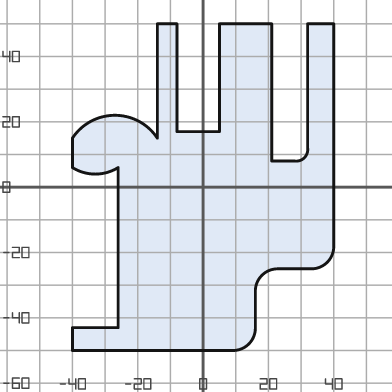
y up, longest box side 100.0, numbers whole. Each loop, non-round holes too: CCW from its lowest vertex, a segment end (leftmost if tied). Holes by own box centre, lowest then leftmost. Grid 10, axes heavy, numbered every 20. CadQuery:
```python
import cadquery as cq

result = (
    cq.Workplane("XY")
    .moveTo(-40.0, -50.0)
    .lineTo(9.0, -50.0)
    .threePointArc((14.0, -48.0), (16.0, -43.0))
    .lineTo(16.0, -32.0)
    .threePointArc((18.0, -27.0), (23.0, -25.0))
    .lineTo(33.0, -25.0)
    .threePointArc((38.0, -23.0), (40.0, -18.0))
    .lineTo(40.0, 50.0)
    .lineTo(32.0, 50.0)
    .lineTo(32.0, 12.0)
    .threePointArc((31.0, 9.0), (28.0, 8.0))
    .lineTo(21.0, 8.0)
    .lineTo(21.0, 50.0)
    .lineTo(5.0, 50.0)
    .lineTo(5.0, 17.0)
    .lineTo(-8.0, 17.0)
    .lineTo(-8.0, 50.0)
    .lineTo(-14.0, 50.0)
    .lineTo(-14.0, 15.0)
    .threePointArc((-27.0, 22.0), (-40.0, 15.0))
    .lineTo(-40.0, 6.0)
    .threePointArc((-33.0, 4.0), (-26.0, 6.0))
    .lineTo(-26.0, -43.0)
    .lineTo(-40.0, -43.0)
    .close()
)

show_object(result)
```